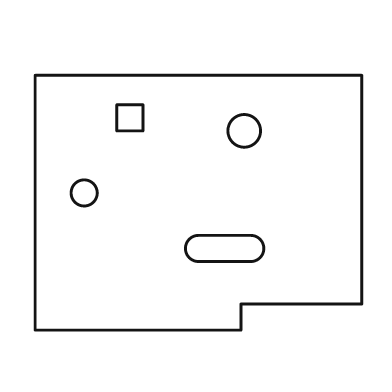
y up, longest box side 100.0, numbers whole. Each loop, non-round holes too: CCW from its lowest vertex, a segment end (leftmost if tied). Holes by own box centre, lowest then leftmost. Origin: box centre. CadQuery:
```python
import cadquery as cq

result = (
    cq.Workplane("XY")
    .moveTo(-50.0, -39.0)
    .lineTo(13.0, -39.0)
    .lineTo(13.0, -31.0)
    .lineTo(50.0, -31.0)
    .lineTo(50.0, 39.0)
    .lineTo(-50.0, 39.0)
    .close()
    .moveTo(0.0, -18.0)
    .lineTo(16.0, -18.0)
    .threePointArc((20.0, -14.0), (16.0, -10.0))
    .lineTo(0.0, -10.0)
    .threePointArc((-4.0, -14.0), (0.0, -18.0))
    .close()
    .moveTo(-35.0, 3.0)
    .circle(4.0)
    .moveTo(14.0, 22.0)
    .circle(5.0)
    .moveTo(-25.0, 22.0)
    .lineTo(-17.0, 22.0)
    .lineTo(-17.0, 30.0)
    .lineTo(-25.0, 30.0)
    .close()
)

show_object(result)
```